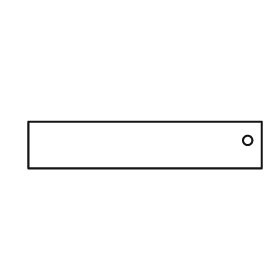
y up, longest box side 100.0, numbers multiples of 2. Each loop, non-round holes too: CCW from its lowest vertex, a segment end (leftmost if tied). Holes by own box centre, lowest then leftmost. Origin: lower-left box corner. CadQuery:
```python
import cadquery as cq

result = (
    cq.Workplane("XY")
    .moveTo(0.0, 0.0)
    .lineTo(100.0, 0.0)
    .lineTo(100.0, 20.0)
    .lineTo(0.0, 20.0)
    .close()
    .moveTo(94.0, 12.0)
    .circle(2.0)
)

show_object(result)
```